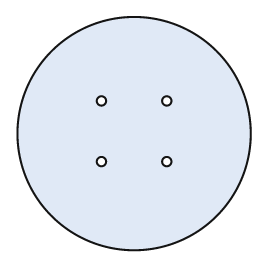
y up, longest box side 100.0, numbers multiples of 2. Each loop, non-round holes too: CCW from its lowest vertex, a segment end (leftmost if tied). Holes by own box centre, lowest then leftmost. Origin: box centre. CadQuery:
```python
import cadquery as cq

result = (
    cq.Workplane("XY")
    .moveTo(0.0, 0.0)
    .circle(50.0)
    .moveTo(-14.0, -12.0)
    .circle(2.0)
    .moveTo(14.0, -12.0)
    .circle(2.0)
    .moveTo(-14.0, 14.0)
    .circle(2.0)
    .moveTo(14.0, 14.0)
    .circle(2.0)
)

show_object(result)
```